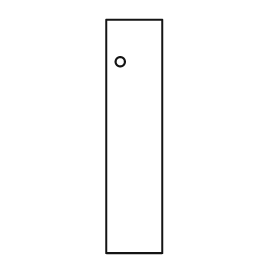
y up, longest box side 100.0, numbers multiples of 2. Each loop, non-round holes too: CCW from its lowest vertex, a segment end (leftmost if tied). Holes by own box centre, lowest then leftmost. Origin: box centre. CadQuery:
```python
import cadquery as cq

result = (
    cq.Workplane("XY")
    .moveTo(-12.0, -50.0)
    .lineTo(12.0, -50.0)
    .lineTo(12.0, 50.0)
    .lineTo(-12.0, 50.0)
    .close()
    .moveTo(-6.0, 32.0)
    .circle(2.0)
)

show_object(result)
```